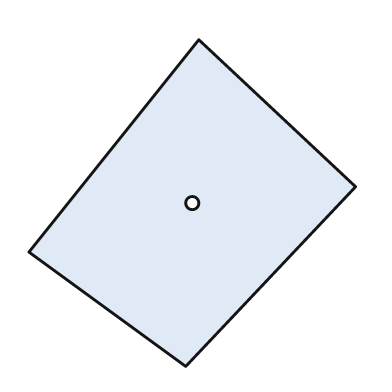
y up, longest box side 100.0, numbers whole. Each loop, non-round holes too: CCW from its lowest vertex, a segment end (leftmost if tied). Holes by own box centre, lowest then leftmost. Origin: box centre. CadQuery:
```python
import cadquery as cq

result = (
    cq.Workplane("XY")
    .moveTo(-2.0, -50.0)
    .lineTo(50.0, 5.0)
    .lineTo(2.0, 50.0)
    .lineTo(-50.0, -15.0)
    .close()
    .moveTo(0.0, 0.0)
    .circle(2.0)
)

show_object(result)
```